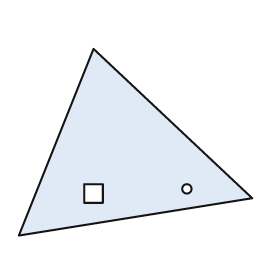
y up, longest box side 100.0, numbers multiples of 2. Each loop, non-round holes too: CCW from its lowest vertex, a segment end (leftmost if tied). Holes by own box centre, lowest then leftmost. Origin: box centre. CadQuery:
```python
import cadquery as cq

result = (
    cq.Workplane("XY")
    .moveTo(-50.0, -40.0)
    .lineTo(50.0, -24.0)
    .lineTo(-18.0, 40.0)
    .close()
    .moveTo(-22.0, -26.0)
    .lineTo(-14.0, -26.0)
    .lineTo(-14.0, -18.0)
    .lineTo(-22.0, -18.0)
    .close()
    .moveTo(22.0, -20.0)
    .circle(2.0)
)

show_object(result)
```